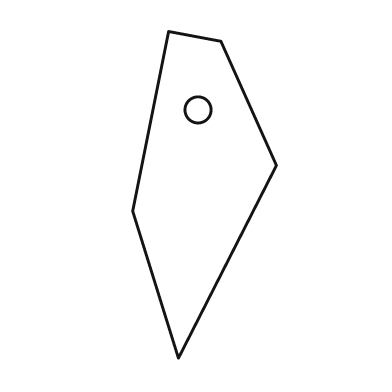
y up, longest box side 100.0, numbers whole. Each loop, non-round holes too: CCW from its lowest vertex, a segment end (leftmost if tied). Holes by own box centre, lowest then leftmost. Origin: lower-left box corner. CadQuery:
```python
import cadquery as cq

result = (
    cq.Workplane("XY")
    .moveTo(14.0, 0.0)
    .lineTo(44.0, 59.0)
    .lineTo(27.0, 97.0)
    .lineTo(11.0, 100.0)
    .lineTo(0.0, 45.0)
    .close()
    .moveTo(20.0, 76.0)
    .circle(4.0)
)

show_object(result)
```